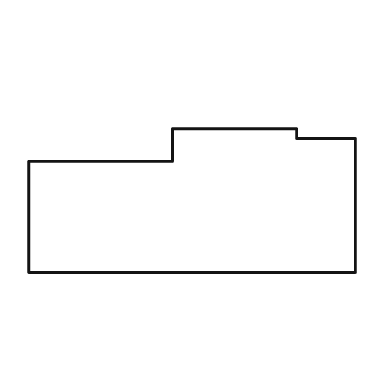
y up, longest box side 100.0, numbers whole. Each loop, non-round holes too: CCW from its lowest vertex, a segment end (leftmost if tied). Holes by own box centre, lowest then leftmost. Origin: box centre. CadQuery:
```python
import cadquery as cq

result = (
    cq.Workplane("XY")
    .moveTo(-50.0, -22.0)
    .lineTo(50.0, -22.0)
    .lineTo(50.0, 19.0)
    .lineTo(32.0, 19.0)
    .lineTo(32.0, 22.0)
    .lineTo(-6.0, 22.0)
    .lineTo(-6.0, 12.0)
    .lineTo(-50.0, 12.0)
    .close()
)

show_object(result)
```